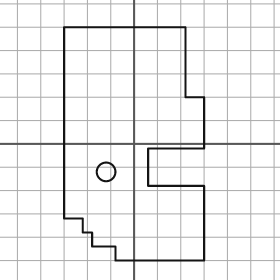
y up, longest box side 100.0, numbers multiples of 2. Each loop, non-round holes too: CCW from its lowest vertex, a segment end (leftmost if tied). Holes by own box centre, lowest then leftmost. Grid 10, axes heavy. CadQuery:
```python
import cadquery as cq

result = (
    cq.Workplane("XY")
    .moveTo(-8.0, -50.0)
    .lineTo(30.0, -50.0)
    .lineTo(30.0, -18.0)
    .lineTo(6.0, -18.0)
    .lineTo(6.0, -2.0)
    .lineTo(30.0, -2.0)
    .lineTo(30.0, 20.0)
    .lineTo(22.0, 20.0)
    .lineTo(22.0, 50.0)
    .lineTo(-30.0, 50.0)
    .lineTo(-30.0, -32.0)
    .lineTo(-22.0, -32.0)
    .lineTo(-22.0, -38.0)
    .lineTo(-18.0, -38.0)
    .lineTo(-18.0, -44.0)
    .lineTo(-8.0, -44.0)
    .close()
    .moveTo(-12.0, -12.0)
    .circle(4.0)
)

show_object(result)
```